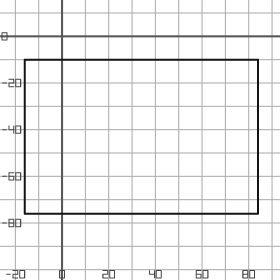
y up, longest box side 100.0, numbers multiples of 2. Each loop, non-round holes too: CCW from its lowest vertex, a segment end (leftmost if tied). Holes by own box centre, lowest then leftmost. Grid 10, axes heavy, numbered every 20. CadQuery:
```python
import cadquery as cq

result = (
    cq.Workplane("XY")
    .moveTo(-16.0, -76.0)
    .lineTo(84.0, -76.0)
    .lineTo(84.0, -10.0)
    .lineTo(-16.0, -10.0)
    .close()
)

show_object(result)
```